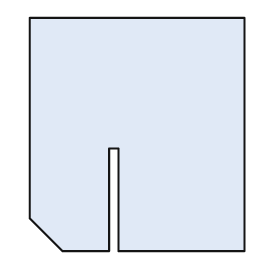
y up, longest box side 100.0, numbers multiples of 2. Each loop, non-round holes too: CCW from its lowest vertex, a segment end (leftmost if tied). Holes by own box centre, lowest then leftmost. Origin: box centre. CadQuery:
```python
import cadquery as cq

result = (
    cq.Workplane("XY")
    .moveTo(-32.0, -50.0)
    .lineTo(-12.0, -50.0)
    .lineTo(-12.0, -6.0)
    .lineTo(-8.0, -6.0)
    .lineTo(-8.0, -50.0)
    .lineTo(46.0, -50.0)
    .lineTo(46.0, 50.0)
    .lineTo(-46.0, 50.0)
    .lineTo(-46.0, -36.0)
    .close()
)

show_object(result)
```